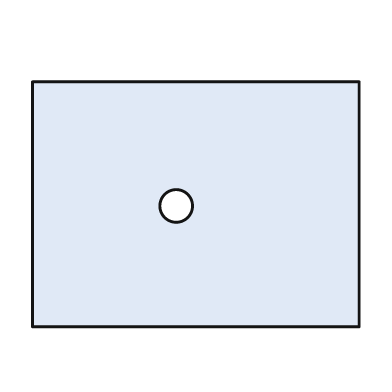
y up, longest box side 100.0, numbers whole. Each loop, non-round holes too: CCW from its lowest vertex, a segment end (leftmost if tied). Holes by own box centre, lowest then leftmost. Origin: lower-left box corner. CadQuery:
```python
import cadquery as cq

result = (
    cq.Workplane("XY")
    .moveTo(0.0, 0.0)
    .lineTo(100.0, 0.0)
    .lineTo(100.0, 75.0)
    .lineTo(0.0, 75.0)
    .close()
    .moveTo(44.0, 37.0)
    .circle(5.0)
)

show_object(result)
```